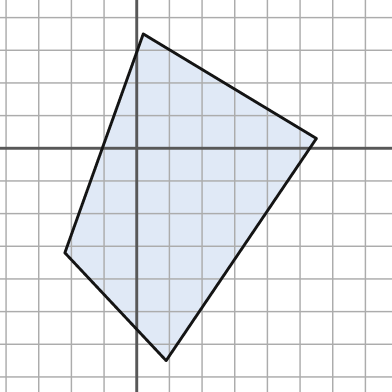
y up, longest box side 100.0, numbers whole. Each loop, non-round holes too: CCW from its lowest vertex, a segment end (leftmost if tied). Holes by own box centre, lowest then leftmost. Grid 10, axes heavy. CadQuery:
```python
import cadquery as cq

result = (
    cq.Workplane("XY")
    .moveTo(9.0, -65.0)
    .lineTo(55.0, 3.0)
    .lineTo(2.0, 35.0)
    .lineTo(-22.0, -32.0)
    .close()
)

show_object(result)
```